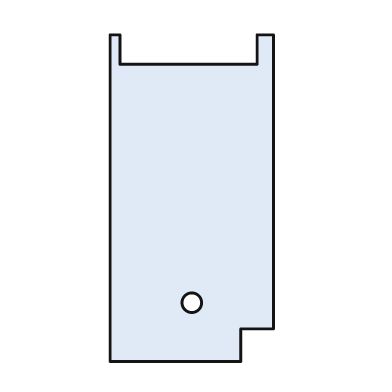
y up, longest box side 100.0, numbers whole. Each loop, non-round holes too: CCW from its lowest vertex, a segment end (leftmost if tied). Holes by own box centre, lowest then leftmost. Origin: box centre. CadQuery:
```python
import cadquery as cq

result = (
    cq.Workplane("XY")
    .moveTo(-25.0, -50.0)
    .lineTo(15.0, -50.0)
    .lineTo(15.0, -40.0)
    .lineTo(25.0, -40.0)
    .lineTo(25.0, 50.0)
    .lineTo(20.0, 50.0)
    .lineTo(20.0, 41.0)
    .lineTo(-22.0, 41.0)
    .lineTo(-22.0, 50.0)
    .lineTo(-25.0, 50.0)
    .close()
    .moveTo(0.0, -32.0)
    .circle(3.0)
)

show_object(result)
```